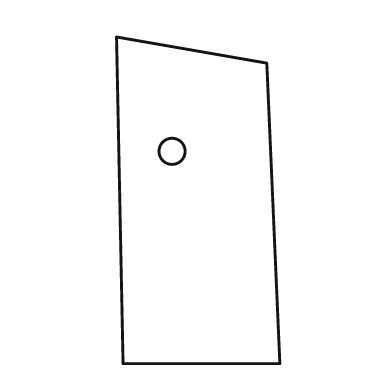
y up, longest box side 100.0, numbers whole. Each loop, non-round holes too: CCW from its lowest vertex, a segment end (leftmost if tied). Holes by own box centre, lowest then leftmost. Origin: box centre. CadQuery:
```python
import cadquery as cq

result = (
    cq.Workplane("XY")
    .moveTo(-23.0, -50.0)
    .lineTo(25.0, -50.0)
    .lineTo(21.0, 42.0)
    .lineTo(-25.0, 50.0)
    .close()
    .moveTo(-8.0, 15.0)
    .circle(4.0)
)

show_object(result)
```